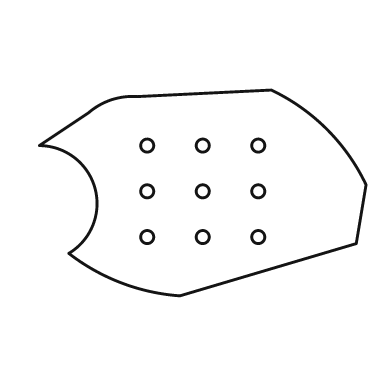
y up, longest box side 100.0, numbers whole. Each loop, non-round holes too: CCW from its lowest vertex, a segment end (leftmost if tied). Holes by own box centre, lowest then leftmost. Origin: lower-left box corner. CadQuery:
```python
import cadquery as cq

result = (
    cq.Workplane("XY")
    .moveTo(43.0, 0.0)
    .lineTo(97.0, 16.0)
    .lineTo(100.0, 34.0)
    .threePointArc((88.0, 51.0), (71.0, 63.0))
    .lineTo(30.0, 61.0)
    .threePointArc((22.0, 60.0), (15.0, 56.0))
    .lineTo(0.0, 46.0)
    .threePointArc((17.0, 33.0), (9.0, 13.0))
    .threePointArc((25.0, 4.0), (43.0, 0.0))
    .close()
    .moveTo(33.0, 18.0)
    .circle(2.0)
    .moveTo(50.0, 18.0)
    .circle(2.0)
    .moveTo(67.0, 18.0)
    .circle(2.0)
    .moveTo(33.0, 32.0)
    .circle(2.0)
    .moveTo(50.0, 32.0)
    .circle(2.0)
    .moveTo(67.0, 32.0)
    .circle(2.0)
    .moveTo(33.0, 46.0)
    .circle(2.0)
    .moveTo(50.0, 46.0)
    .circle(2.0)
    .moveTo(67.0, 46.0)
    .circle(2.0)
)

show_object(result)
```